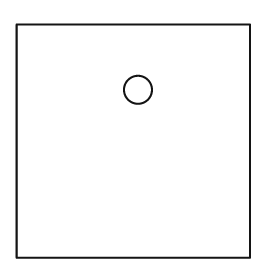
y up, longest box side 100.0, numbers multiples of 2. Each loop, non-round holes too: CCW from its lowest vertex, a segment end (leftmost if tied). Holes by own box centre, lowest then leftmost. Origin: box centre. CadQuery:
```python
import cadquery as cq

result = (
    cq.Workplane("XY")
    .moveTo(-50.0, -50.0)
    .lineTo(50.0, -50.0)
    .lineTo(50.0, 50.0)
    .lineTo(-50.0, 50.0)
    .close()
    .moveTo(2.0, 22.0)
    .circle(6.0)
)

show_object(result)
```